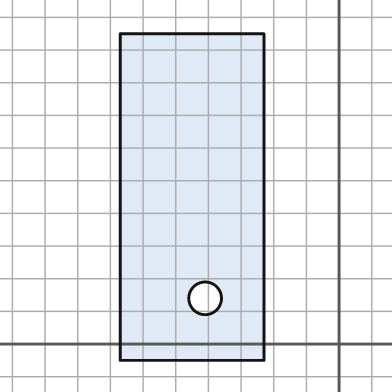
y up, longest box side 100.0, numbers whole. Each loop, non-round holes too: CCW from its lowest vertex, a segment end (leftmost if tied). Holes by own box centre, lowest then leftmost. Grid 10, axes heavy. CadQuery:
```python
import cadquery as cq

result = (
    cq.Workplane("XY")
    .moveTo(-67.0, -5.0)
    .lineTo(-23.0, -5.0)
    .lineTo(-23.0, 95.0)
    .lineTo(-67.0, 95.0)
    .close()
    .moveTo(-41.0, 14.0)
    .circle(5.0)
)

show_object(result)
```